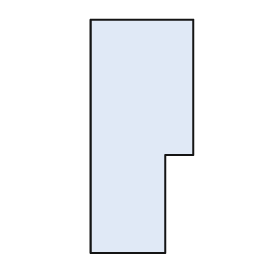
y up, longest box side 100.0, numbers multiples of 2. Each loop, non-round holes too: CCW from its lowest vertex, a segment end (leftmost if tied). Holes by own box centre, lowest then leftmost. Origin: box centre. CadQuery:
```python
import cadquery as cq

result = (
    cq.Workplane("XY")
    .moveTo(-22.0, -50.0)
    .lineTo(10.0, -50.0)
    .lineTo(10.0, -8.0)
    .lineTo(22.0, -8.0)
    .lineTo(22.0, 50.0)
    .lineTo(-22.0, 50.0)
    .close()
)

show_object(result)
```